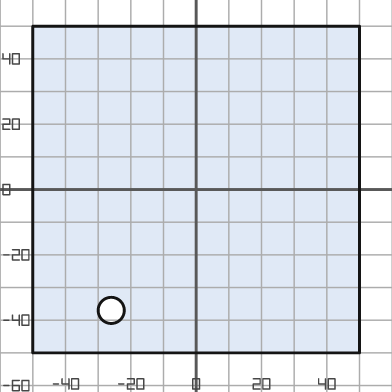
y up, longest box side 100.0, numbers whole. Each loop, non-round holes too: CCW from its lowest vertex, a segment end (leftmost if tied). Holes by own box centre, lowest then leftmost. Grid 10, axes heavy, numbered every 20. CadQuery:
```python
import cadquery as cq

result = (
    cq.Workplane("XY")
    .moveTo(-50.0, -50.0)
    .lineTo(50.0, -50.0)
    .lineTo(50.0, 50.0)
    .lineTo(-50.0, 50.0)
    .close()
    .moveTo(-26.0, -37.0)
    .circle(4.0)
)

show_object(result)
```